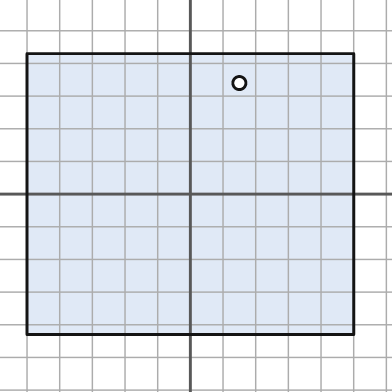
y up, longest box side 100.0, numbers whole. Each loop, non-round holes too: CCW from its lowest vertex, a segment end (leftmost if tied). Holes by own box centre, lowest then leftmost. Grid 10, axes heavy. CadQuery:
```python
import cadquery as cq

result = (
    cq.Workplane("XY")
    .moveTo(-50.0, -43.0)
    .lineTo(50.0, -43.0)
    .lineTo(50.0, 43.0)
    .lineTo(-50.0, 43.0)
    .close()
    .moveTo(15.0, 34.0)
    .circle(2.0)
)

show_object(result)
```